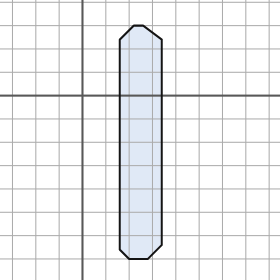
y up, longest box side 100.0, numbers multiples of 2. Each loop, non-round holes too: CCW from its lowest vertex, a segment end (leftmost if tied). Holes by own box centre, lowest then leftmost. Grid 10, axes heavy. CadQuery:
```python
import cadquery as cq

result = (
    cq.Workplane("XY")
    .moveTo(20.0, -70.0)
    .lineTo(28.0, -70.0)
    .lineTo(34.0, -64.0)
    .lineTo(34.0, 24.0)
    .lineTo(26.0, 30.0)
    .lineTo(22.0, 30.0)
    .lineTo(16.0, 24.0)
    .lineTo(16.0, -66.0)
    .close()
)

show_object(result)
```